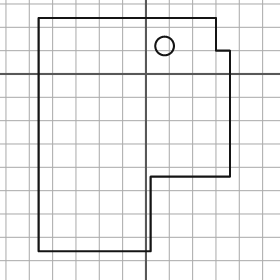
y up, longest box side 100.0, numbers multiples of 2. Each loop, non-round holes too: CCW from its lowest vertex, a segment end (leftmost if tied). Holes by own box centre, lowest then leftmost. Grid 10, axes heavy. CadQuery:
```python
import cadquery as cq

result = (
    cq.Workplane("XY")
    .moveTo(-46.0, -76.0)
    .lineTo(2.0, -76.0)
    .lineTo(2.0, -44.0)
    .lineTo(36.0, -44.0)
    .lineTo(36.0, 10.0)
    .lineTo(30.0, 10.0)
    .lineTo(30.0, 24.0)
    .lineTo(-46.0, 24.0)
    .close()
    .moveTo(8.0, 12.0)
    .circle(4.0)
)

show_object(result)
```